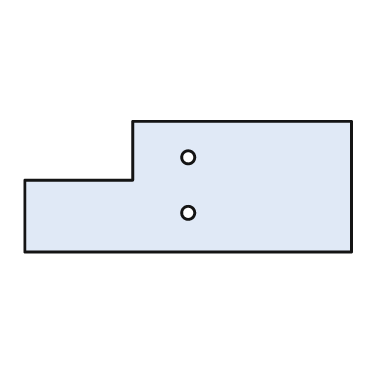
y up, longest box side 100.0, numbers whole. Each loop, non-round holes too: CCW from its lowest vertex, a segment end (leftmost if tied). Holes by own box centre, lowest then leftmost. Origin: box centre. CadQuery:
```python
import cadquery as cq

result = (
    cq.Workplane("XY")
    .moveTo(-50.0, -20.0)
    .lineTo(50.0, -20.0)
    .lineTo(50.0, 20.0)
    .lineTo(-17.0, 20.0)
    .lineTo(-17.0, 2.0)
    .lineTo(-50.0, 2.0)
    .close()
    .moveTo(0.0, -8.0)
    .circle(2.0)
    .moveTo(0.0, 9.0)
    .circle(2.0)
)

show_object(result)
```